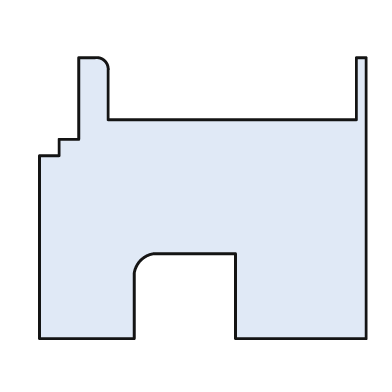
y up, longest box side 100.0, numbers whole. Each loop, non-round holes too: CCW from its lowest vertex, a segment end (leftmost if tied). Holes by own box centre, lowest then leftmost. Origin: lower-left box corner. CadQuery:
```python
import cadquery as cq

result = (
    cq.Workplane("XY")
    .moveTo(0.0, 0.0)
    .lineTo(29.0, 0.0)
    .lineTo(29.0, 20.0)
    .threePointArc((31.0, 24.0), (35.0, 26.0))
    .lineTo(60.0, 26.0)
    .lineTo(60.0, 0.0)
    .lineTo(100.0, 0.0)
    .lineTo(100.0, 86.0)
    .lineTo(97.0, 86.0)
    .lineTo(97.0, 67.0)
    .lineTo(21.0, 67.0)
    .lineTo(21.0, 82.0)
    .threePointArc((20.0, 85.0), (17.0, 86.0))
    .lineTo(12.0, 86.0)
    .lineTo(12.0, 61.0)
    .lineTo(6.0, 61.0)
    .lineTo(6.0, 56.0)
    .lineTo(0.0, 56.0)
    .close()
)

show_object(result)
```